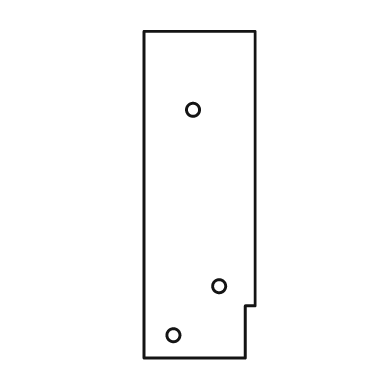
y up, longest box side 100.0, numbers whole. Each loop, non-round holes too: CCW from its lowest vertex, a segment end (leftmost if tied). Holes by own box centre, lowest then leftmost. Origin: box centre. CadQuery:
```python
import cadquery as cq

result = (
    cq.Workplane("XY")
    .moveTo(-17.0, -50.0)
    .lineTo(14.0, -50.0)
    .lineTo(14.0, -34.0)
    .lineTo(17.0, -34.0)
    .lineTo(17.0, 50.0)
    .lineTo(-17.0, 50.0)
    .close()
    .moveTo(-8.0, -43.0)
    .circle(2.0)
    .moveTo(6.0, -28.0)
    .circle(2.0)
    .moveTo(-2.0, 26.0)
    .circle(2.0)
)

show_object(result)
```